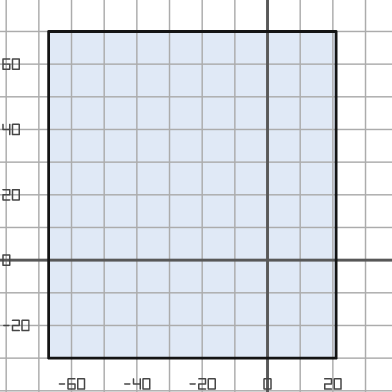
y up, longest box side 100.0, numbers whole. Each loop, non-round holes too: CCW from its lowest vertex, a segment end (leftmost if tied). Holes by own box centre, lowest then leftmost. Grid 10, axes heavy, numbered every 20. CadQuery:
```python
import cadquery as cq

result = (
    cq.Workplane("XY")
    .moveTo(-67.0, -30.0)
    .lineTo(21.0, -30.0)
    .lineTo(21.0, 70.0)
    .lineTo(-67.0, 70.0)
    .close()
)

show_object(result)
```